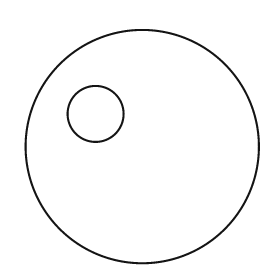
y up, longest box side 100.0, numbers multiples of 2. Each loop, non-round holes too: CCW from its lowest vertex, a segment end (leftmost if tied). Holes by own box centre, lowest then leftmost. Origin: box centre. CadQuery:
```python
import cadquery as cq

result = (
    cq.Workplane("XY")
    .moveTo(0.0, 0.0)
    .circle(50.0)
    .moveTo(-20.0, 14.0)
    .circle(12.0)
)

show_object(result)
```